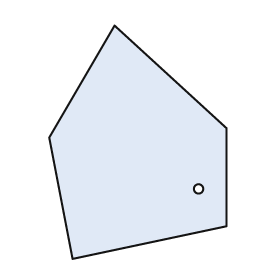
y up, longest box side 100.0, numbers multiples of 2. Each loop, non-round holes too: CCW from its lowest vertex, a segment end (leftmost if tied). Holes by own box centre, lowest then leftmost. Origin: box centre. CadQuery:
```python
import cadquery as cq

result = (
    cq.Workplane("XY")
    .moveTo(-28.0, -50.0)
    .lineTo(38.0, -36.0)
    .lineTo(38.0, 6.0)
    .lineTo(-10.0, 50.0)
    .lineTo(-38.0, 2.0)
    .close()
    .moveTo(26.0, -20.0)
    .circle(2.0)
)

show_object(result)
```